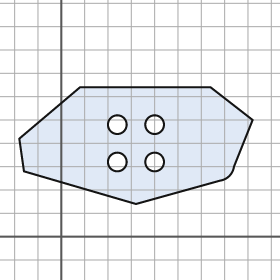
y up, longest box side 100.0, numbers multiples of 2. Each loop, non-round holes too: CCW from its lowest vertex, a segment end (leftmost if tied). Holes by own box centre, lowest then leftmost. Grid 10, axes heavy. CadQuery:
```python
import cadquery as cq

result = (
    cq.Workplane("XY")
    .moveTo(32.0, 14.0)
    .lineTo(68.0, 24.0)
    .threePointArc((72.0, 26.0), (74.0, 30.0))
    .lineTo(82.0, 50.0)
    .lineTo(64.0, 64.0)
    .lineTo(8.0, 64.0)
    .lineTo(-18.0, 42.0)
    .lineTo(-16.0, 28.0)
    .close()
    .moveTo(24.0, 32.0)
    .circle(4.0)
    .moveTo(40.0, 32.0)
    .circle(4.0)
    .moveTo(24.0, 48.0)
    .circle(4.0)
    .moveTo(40.0, 48.0)
    .circle(4.0)
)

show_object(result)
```